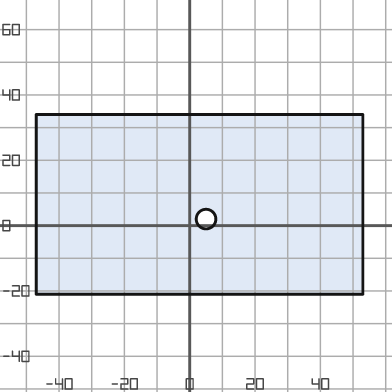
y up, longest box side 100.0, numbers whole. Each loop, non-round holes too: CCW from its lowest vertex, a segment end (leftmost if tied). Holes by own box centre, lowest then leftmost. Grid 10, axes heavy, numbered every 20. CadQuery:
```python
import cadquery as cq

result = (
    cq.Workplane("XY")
    .moveTo(-47.0, -21.0)
    .lineTo(53.0, -21.0)
    .lineTo(53.0, 34.0)
    .lineTo(-47.0, 34.0)
    .close()
    .moveTo(5.0, 2.0)
    .circle(3.0)
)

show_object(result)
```